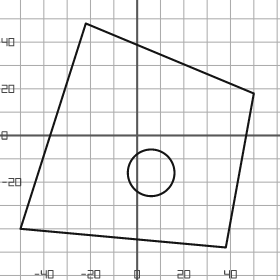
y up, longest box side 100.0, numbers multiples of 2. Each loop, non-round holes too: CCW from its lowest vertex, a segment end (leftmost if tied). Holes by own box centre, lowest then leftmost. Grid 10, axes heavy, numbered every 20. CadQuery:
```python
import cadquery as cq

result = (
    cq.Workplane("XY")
    .moveTo(38.0, -48.0)
    .lineTo(50.0, 18.0)
    .lineTo(-22.0, 48.0)
    .lineTo(-50.0, -40.0)
    .close()
    .moveTo(6.0, -16.0)
    .circle(10.0)
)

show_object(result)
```